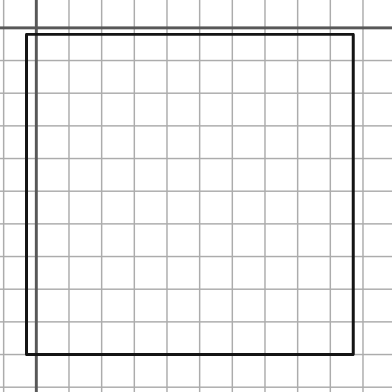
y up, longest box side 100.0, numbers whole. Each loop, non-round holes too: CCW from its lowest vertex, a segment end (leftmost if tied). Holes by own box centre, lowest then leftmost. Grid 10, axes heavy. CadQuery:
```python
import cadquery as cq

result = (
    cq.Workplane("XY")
    .moveTo(-3.0, -100.0)
    .lineTo(97.0, -100.0)
    .lineTo(97.0, -2.0)
    .lineTo(-3.0, -2.0)
    .close()
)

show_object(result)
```